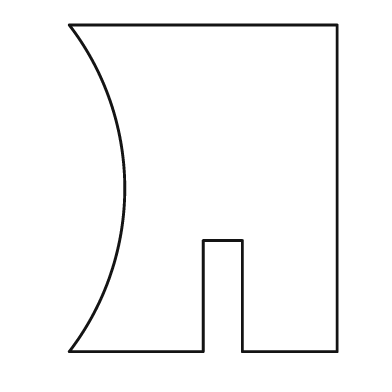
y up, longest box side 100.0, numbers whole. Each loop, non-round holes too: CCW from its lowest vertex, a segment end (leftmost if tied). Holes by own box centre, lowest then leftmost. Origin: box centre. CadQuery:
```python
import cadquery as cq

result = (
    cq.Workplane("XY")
    .moveTo(-41.0, -50.0)
    .lineTo(0.0, -50.0)
    .lineTo(0.0, -16.0)
    .lineTo(12.0, -16.0)
    .lineTo(12.0, -50.0)
    .lineTo(41.0, -50.0)
    .lineTo(41.0, 50.0)
    .lineTo(-41.0, 50.0)
    .threePointArc((-24.0, 0.0), (-41.0, -50.0))
    .close()
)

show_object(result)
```